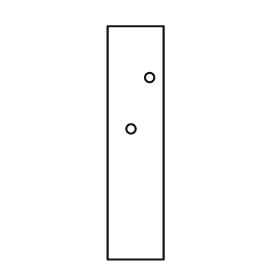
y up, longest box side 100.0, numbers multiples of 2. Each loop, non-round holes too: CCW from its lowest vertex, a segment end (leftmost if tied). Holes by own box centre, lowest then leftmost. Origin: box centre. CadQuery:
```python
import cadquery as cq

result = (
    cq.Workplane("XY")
    .moveTo(-12.0, -50.0)
    .lineTo(12.0, -50.0)
    .lineTo(12.0, 50.0)
    .lineTo(-12.0, 50.0)
    .close()
    .moveTo(-2.0, 6.0)
    .circle(2.0)
    .moveTo(6.0, 28.0)
    .circle(2.0)
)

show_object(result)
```